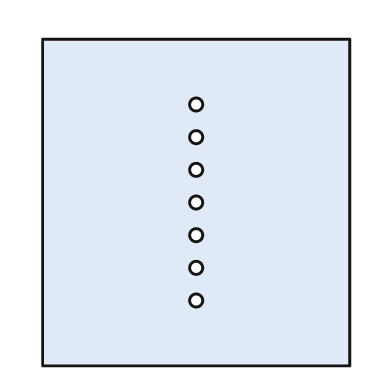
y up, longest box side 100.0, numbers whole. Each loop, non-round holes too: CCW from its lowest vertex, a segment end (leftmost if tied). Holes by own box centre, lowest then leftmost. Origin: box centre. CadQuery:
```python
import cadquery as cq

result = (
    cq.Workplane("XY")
    .moveTo(-47.0, -50.0)
    .lineTo(47.0, -50.0)
    .lineTo(47.0, 50.0)
    .lineTo(-47.0, 50.0)
    .close()
    .moveTo(0.0, -30.0)
    .circle(2.0)
    .moveTo(0.0, -20.0)
    .circle(2.0)
    .moveTo(0.0, -10.0)
    .circle(2.0)
    .moveTo(0.0, 0.0)
    .circle(2.0)
    .moveTo(0.0, 10.0)
    .circle(2.0)
    .moveTo(0.0, 20.0)
    .circle(2.0)
    .moveTo(0.0, 30.0)
    .circle(2.0)
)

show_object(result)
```